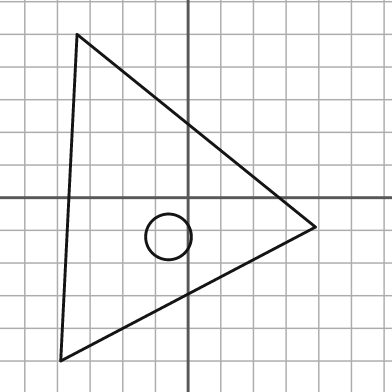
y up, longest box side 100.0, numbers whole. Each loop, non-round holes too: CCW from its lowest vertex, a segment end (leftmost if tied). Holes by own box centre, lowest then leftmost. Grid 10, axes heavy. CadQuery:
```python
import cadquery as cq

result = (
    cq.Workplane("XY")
    .moveTo(-39.0, -50.0)
    .lineTo(39.0, -9.0)
    .lineTo(-34.0, 50.0)
    .close()
    .moveTo(-6.0, -12.0)
    .circle(7.0)
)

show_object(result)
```